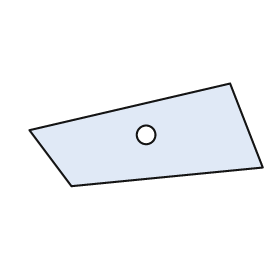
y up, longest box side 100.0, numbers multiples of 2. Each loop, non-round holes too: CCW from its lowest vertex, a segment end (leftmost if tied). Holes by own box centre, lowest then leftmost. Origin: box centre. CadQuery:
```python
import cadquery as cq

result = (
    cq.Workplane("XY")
    .moveTo(-32.0, -22.0)
    .lineTo(50.0, -14.0)
    .lineTo(36.0, 22.0)
    .lineTo(-50.0, 2.0)
    .close()
    .moveTo(0.0, 0.0)
    .circle(4.0)
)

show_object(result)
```